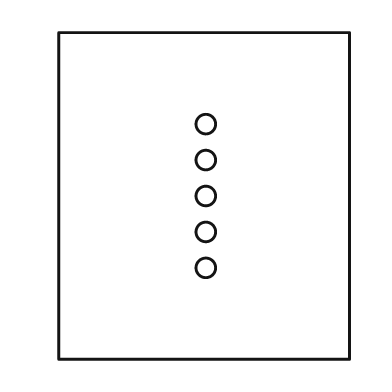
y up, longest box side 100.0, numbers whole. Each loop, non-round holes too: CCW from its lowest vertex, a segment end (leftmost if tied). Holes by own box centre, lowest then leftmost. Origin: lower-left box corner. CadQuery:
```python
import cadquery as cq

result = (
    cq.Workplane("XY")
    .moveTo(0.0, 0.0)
    .lineTo(89.0, 0.0)
    .lineTo(89.0, 100.0)
    .lineTo(0.0, 100.0)
    .close()
    .moveTo(45.0, 28.0)
    .circle(3.0)
    .moveTo(45.0, 39.0)
    .circle(3.0)
    .moveTo(45.0, 50.0)
    .circle(3.0)
    .moveTo(45.0, 61.0)
    .circle(3.0)
    .moveTo(45.0, 72.0)
    .circle(3.0)
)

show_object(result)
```